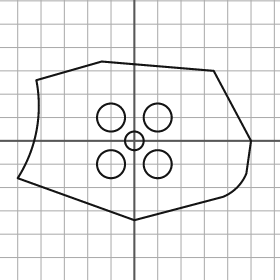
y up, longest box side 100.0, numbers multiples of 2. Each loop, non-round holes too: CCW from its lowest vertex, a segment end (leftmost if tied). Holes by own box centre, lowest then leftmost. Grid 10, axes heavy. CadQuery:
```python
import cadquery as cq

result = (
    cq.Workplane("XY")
    .moveTo(0.0, -34.0)
    .lineTo(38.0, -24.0)
    .threePointArc((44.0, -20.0), (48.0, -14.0))
    .lineTo(50.0, 0.0)
    .lineTo(34.0, 30.0)
    .lineTo(-14.0, 34.0)
    .lineTo(-42.0, 26.0)
    .threePointArc((-42.0, 4.0), (-50.0, -16.0))
    .close()
    .moveTo(-10.0, -10.0)
    .circle(6.0)
    .moveTo(10.0, -10.0)
    .circle(6.0)
    .moveTo(0.0, 0.0)
    .circle(4.0)
    .moveTo(-10.0, 10.0)
    .circle(6.0)
    .moveTo(10.0, 10.0)
    .circle(6.0)
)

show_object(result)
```